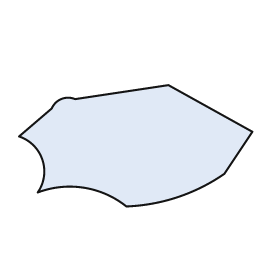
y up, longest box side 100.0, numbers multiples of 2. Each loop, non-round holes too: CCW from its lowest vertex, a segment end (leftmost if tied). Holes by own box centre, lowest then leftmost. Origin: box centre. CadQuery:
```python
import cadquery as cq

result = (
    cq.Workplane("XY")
    .moveTo(-4.0, -26.0)
    .threePointArc((18.0, -22.0), (38.0, -12.0))
    .lineTo(50.0, 6.0)
    .lineTo(14.0, 26.0)
    .lineTo(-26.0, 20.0)
    .threePointArc((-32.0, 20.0), (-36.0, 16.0))
    .lineTo(-50.0, 4.0)
    .threePointArc((-40.0, -6.0), (-42.0, -20.0))
    .threePointArc((-22.0, -18.0), (-4.0, -26.0))
    .close()
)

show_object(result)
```